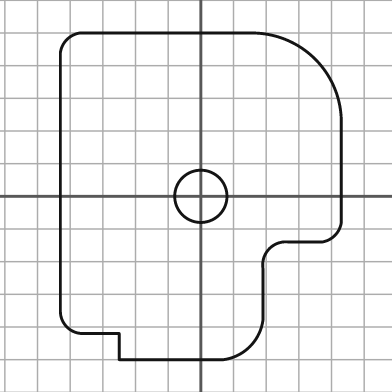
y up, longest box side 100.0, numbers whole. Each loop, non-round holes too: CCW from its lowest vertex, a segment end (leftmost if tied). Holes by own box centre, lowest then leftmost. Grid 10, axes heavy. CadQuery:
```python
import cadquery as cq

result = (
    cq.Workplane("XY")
    .moveTo(-25.0, -50.0)
    .lineTo(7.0, -50.0)
    .threePointArc((15.0, -46.0), (19.0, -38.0))
    .lineTo(19.0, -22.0)
    .threePointArc((21.0, -16.0), (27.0, -14.0))
    .lineTo(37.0, -14.0)
    .threePointArc((41.0, -12.0), (43.0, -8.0))
    .lineTo(43.0, 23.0)
    .threePointArc((35.0, 42.0), (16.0, 50.0))
    .lineTo(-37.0, 50.0)
    .threePointArc((-41.0, 48.0), (-43.0, 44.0))
    .lineTo(-43.0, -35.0)
    .threePointArc((-41.0, -40.0), (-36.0, -42.0))
    .lineTo(-25.0, -42.0)
    .close()
    .moveTo(0.0, 0.0)
    .circle(8.0)
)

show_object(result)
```